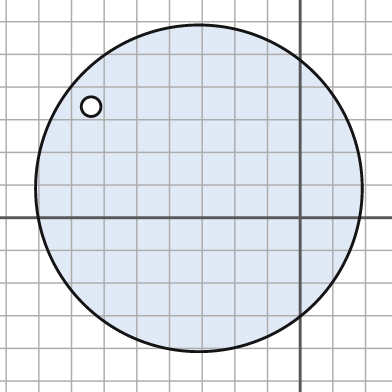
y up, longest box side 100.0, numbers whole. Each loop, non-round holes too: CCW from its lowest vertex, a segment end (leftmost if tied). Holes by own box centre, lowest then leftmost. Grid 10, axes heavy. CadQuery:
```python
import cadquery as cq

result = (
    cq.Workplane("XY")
    .moveTo(-31.0, 9.0)
    .circle(50.0)
    .moveTo(-64.0, 34.0)
    .circle(3.0)
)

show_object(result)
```